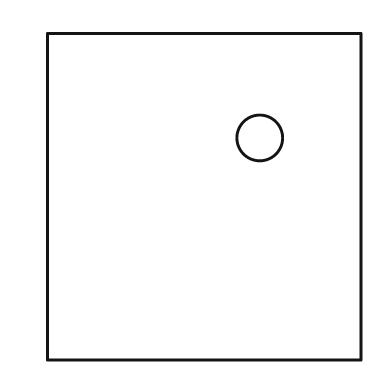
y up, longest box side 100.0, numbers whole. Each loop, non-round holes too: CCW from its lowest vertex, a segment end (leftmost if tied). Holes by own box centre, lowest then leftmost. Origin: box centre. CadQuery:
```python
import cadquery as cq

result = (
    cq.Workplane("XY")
    .moveTo(-48.0, -50.0)
    .lineTo(48.0, -50.0)
    .lineTo(48.0, 50.0)
    .lineTo(-48.0, 50.0)
    .close()
    .moveTo(17.0, 18.0)
    .circle(7.0)
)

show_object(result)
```